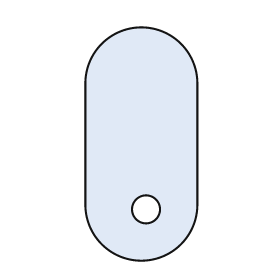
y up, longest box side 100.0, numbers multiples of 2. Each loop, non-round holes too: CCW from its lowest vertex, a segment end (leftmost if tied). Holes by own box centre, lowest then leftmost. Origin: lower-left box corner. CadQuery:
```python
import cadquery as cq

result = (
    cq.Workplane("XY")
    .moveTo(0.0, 24.0)
    .threePointArc((24.0, 0.0), (48.0, 24.0))
    .lineTo(48.0, 76.0)
    .threePointArc((24.0, 100.0), (0.0, 76.0))
    .close()
    .moveTo(26.0, 22.0)
    .circle(6.0)
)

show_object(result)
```